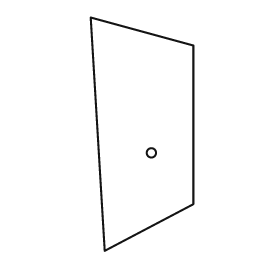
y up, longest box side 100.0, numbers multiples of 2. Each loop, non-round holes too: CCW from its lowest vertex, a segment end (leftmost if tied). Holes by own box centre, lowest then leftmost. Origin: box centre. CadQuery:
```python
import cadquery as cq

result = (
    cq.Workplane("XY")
    .moveTo(-16.0, -50.0)
    .lineTo(22.0, -30.0)
    .lineTo(22.0, 38.0)
    .lineTo(-22.0, 50.0)
    .close()
    .moveTo(4.0, -8.0)
    .circle(2.0)
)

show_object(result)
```